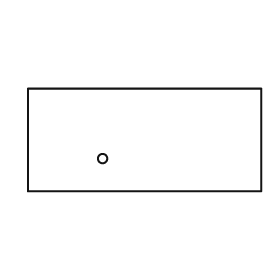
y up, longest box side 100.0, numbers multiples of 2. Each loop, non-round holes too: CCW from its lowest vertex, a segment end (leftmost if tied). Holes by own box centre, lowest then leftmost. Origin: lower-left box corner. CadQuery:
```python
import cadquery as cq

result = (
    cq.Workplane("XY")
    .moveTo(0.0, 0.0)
    .lineTo(100.0, 0.0)
    .lineTo(100.0, 44.0)
    .lineTo(0.0, 44.0)
    .close()
    .moveTo(32.0, 14.0)
    .circle(2.0)
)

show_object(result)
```